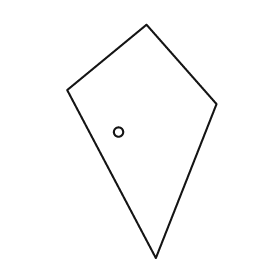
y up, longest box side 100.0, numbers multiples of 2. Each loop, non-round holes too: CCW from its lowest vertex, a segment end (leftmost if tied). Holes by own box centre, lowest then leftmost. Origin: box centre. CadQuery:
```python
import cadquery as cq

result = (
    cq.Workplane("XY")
    .moveTo(6.0, -50.0)
    .lineTo(32.0, 16.0)
    .lineTo(2.0, 50.0)
    .lineTo(-32.0, 22.0)
    .close()
    .moveTo(-10.0, 4.0)
    .circle(2.0)
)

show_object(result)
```